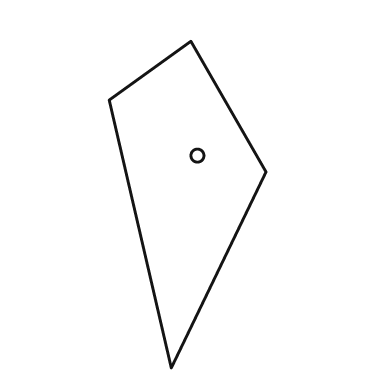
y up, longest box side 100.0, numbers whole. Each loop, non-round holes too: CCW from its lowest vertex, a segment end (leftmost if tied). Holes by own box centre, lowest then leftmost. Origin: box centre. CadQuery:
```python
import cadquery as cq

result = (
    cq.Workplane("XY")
    .moveTo(-5.0, -50.0)
    .lineTo(24.0, 10.0)
    .lineTo(1.0, 50.0)
    .lineTo(-24.0, 32.0)
    .close()
    .moveTo(3.0, 15.0)
    .circle(2.0)
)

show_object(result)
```